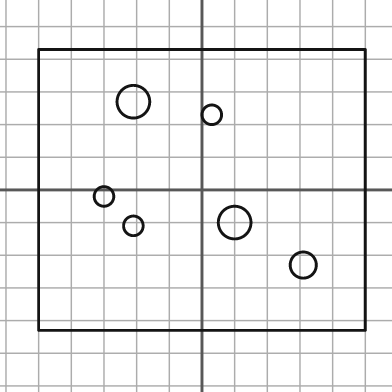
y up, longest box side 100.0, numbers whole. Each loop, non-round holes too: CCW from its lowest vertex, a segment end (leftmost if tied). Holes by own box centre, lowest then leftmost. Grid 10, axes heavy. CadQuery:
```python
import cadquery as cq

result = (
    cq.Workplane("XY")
    .moveTo(-50.0, -43.0)
    .lineTo(50.0, -43.0)
    .lineTo(50.0, 43.0)
    .lineTo(-50.0, 43.0)
    .close()
    .moveTo(31.0, -23.0)
    .circle(4.0)
    .moveTo(-21.0, -11.0)
    .circle(3.0)
    .moveTo(10.0, -10.0)
    .circle(5.0)
    .moveTo(-30.0, -2.0)
    .circle(3.0)
    .moveTo(3.0, 23.0)
    .circle(3.0)
    .moveTo(-21.0, 27.0)
    .circle(5.0)
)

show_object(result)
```